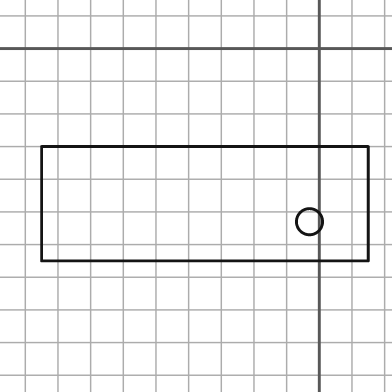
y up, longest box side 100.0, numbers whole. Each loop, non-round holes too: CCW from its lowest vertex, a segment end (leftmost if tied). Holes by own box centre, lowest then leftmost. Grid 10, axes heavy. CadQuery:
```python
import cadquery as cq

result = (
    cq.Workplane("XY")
    .moveTo(-85.0, -65.0)
    .lineTo(15.0, -65.0)
    .lineTo(15.0, -30.0)
    .lineTo(-85.0, -30.0)
    .close()
    .moveTo(-3.0, -53.0)
    .circle(4.0)
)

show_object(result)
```